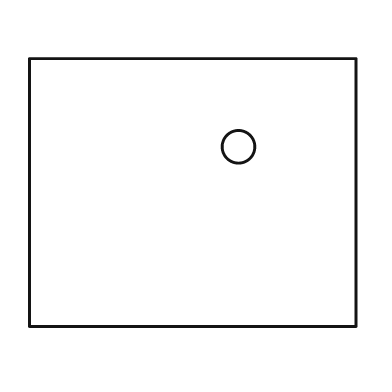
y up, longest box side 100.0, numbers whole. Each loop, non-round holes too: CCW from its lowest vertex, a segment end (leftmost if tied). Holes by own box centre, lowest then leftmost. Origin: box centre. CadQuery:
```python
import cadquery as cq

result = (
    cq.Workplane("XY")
    .moveTo(-50.0, -41.0)
    .lineTo(50.0, -41.0)
    .lineTo(50.0, 41.0)
    .lineTo(-50.0, 41.0)
    .close()
    .moveTo(14.0, 14.0)
    .circle(5.0)
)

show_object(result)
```